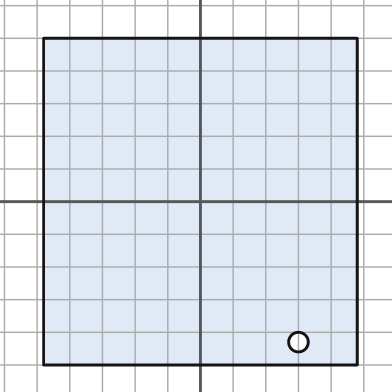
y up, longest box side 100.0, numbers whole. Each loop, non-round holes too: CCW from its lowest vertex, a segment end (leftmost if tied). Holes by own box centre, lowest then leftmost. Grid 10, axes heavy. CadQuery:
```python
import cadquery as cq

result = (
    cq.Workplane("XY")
    .moveTo(-48.0, -50.0)
    .lineTo(48.0, -50.0)
    .lineTo(48.0, 50.0)
    .lineTo(-48.0, 50.0)
    .close()
    .moveTo(30.0, -43.0)
    .circle(3.0)
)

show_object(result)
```